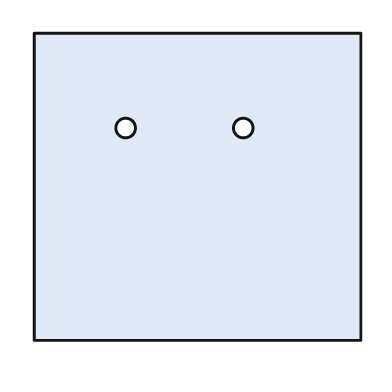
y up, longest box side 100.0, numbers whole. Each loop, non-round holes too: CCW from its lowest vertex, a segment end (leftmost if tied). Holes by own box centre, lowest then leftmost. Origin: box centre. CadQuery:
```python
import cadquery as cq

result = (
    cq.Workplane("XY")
    .moveTo(-50.0, -47.0)
    .lineTo(50.0, -47.0)
    .lineTo(50.0, 47.0)
    .lineTo(-50.0, 47.0)
    .close()
    .moveTo(-22.0, 18.0)
    .circle(3.0)
    .moveTo(14.0, 18.0)
    .circle(3.0)
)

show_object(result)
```